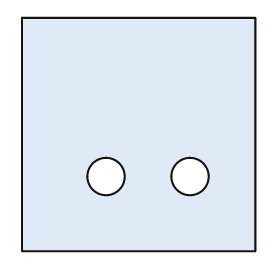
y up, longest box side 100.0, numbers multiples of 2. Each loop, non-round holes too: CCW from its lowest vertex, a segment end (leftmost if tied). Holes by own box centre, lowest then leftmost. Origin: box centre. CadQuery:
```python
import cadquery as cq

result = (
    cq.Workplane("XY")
    .moveTo(-50.0, -50.0)
    .lineTo(50.0, -50.0)
    .lineTo(50.0, 50.0)
    .lineTo(-50.0, 50.0)
    .close()
    .moveTo(-14.0, -18.0)
    .circle(8.0)
    .moveTo(22.0, -18.0)
    .circle(8.0)
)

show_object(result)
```